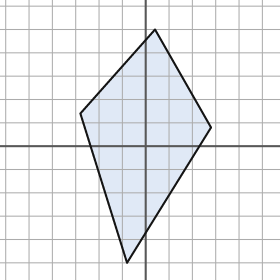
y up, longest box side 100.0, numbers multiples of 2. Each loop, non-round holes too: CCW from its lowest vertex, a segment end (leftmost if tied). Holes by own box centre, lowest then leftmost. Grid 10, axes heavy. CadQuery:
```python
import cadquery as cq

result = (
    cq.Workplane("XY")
    .moveTo(-8.0, -50.0)
    .lineTo(28.0, 8.0)
    .lineTo(4.0, 50.0)
    .lineTo(-28.0, 14.0)
    .close()
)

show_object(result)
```